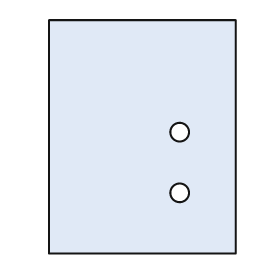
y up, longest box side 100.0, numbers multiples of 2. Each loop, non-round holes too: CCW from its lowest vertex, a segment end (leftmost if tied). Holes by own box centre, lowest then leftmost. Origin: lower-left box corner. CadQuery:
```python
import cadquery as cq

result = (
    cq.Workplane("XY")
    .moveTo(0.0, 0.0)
    .lineTo(80.0, 0.0)
    .lineTo(80.0, 100.0)
    .lineTo(0.0, 100.0)
    .close()
    .moveTo(56.0, 26.0)
    .circle(4.0)
    .moveTo(56.0, 52.0)
    .circle(4.0)
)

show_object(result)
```